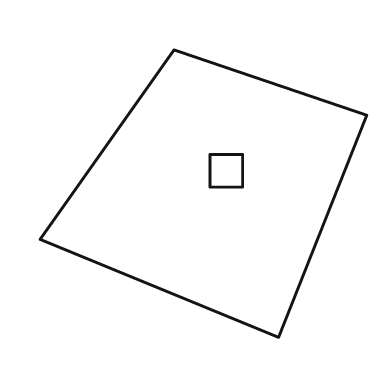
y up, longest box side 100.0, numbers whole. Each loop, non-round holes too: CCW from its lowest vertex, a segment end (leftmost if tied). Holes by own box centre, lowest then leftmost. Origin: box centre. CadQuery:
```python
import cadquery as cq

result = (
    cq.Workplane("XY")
    .moveTo(23.0, -44.0)
    .lineTo(50.0, 24.0)
    .lineTo(-9.0, 44.0)
    .lineTo(-50.0, -14.0)
    .close()
    .moveTo(2.0, 2.0)
    .lineTo(12.0, 2.0)
    .lineTo(12.0, 12.0)
    .lineTo(2.0, 12.0)
    .close()
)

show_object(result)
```